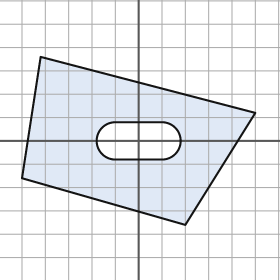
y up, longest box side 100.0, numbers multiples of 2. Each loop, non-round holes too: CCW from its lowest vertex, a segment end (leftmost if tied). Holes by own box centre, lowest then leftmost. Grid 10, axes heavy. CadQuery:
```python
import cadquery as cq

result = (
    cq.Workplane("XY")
    .moveTo(20.0, -36.0)
    .lineTo(50.0, 12.0)
    .lineTo(-42.0, 36.0)
    .lineTo(-50.0, -16.0)
    .close()
    .moveTo(-10.0, -8.0)
    .lineTo(10.0, -8.0)
    .threePointArc((18.0, 0.0), (10.0, 8.0))
    .lineTo(-10.0, 8.0)
    .threePointArc((-18.0, 0.0), (-10.0, -8.0))
    .close()
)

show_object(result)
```